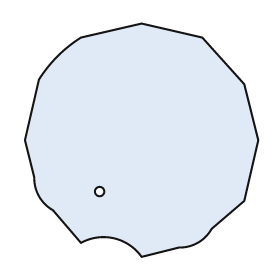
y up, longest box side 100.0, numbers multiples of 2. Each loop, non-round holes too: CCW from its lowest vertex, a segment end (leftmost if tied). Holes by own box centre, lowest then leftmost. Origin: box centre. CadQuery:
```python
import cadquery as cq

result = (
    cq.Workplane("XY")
    .moveTo(0.0, -50.0)
    .lineTo(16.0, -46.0)
    .threePointArc((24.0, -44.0), (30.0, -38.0))
    .lineTo(44.0, -26.0)
    .lineTo(50.0, 0.0)
    .lineTo(44.0, 24.0)
    .lineTo(26.0, 44.0)
    .lineTo(0.0, 50.0)
    .lineTo(-26.0, 44.0)
    .threePointArc((-36.0, 36.0), (-44.0, 26.0))
    .lineTo(-50.0, 0.0)
    .lineTo(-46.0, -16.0)
    .threePointArc((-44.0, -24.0), (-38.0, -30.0))
    .lineTo(-26.0, -44.0)
    .threePointArc((-12.0, -42.0), (0.0, -50.0))
    .close()
    .moveTo(-18.0, -22.0)
    .circle(2.0)
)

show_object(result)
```